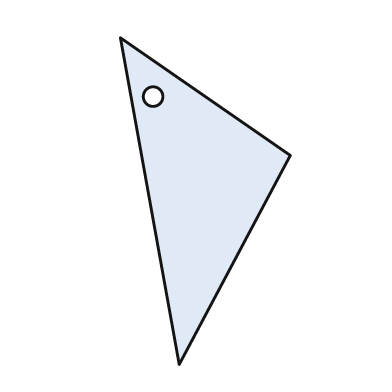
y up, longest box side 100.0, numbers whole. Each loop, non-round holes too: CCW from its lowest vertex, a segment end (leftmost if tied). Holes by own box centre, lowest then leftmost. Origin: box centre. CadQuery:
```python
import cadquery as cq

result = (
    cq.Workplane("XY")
    .moveTo(-8.0, -50.0)
    .lineTo(26.0, 14.0)
    .lineTo(-26.0, 50.0)
    .close()
    .moveTo(-16.0, 32.0)
    .circle(3.0)
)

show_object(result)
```